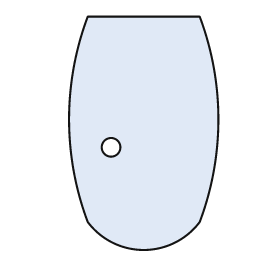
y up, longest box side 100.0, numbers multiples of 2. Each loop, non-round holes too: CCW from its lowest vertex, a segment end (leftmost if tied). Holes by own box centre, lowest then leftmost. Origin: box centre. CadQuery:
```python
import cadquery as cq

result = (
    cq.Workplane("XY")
    .moveTo(-24.0, -38.0)
    .threePointArc((0.0, -50.0), (24.0, -38.0))
    .threePointArc((32.0, 6.0), (24.0, 50.0))
    .lineTo(-24.0, 50.0)
    .threePointArc((-32.0, 6.0), (-24.0, -38.0))
    .close()
    .moveTo(-14.0, -6.0)
    .circle(4.0)
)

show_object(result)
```